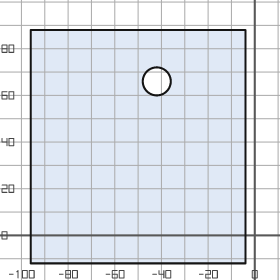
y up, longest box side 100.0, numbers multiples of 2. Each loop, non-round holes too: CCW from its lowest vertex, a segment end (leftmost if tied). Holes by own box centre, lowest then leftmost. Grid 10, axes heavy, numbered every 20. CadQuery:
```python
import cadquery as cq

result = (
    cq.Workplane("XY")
    .moveTo(-96.0, -12.0)
    .lineTo(-4.0, -12.0)
    .lineTo(-4.0, 88.0)
    .lineTo(-96.0, 88.0)
    .close()
    .moveTo(-42.0, 66.0)
    .circle(6.0)
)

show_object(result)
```